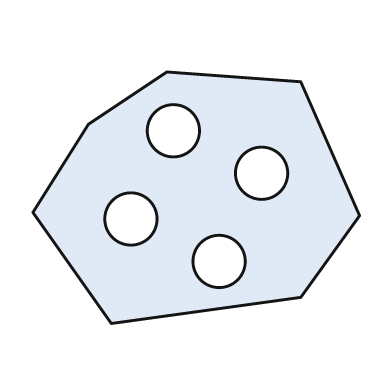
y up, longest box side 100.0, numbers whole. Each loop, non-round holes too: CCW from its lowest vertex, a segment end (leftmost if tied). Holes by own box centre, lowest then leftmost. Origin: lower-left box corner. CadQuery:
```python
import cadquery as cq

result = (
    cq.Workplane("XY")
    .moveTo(24.0, 0.0)
    .lineTo(82.0, 8.0)
    .lineTo(100.0, 33.0)
    .lineTo(82.0, 74.0)
    .lineTo(41.0, 77.0)
    .lineTo(17.0, 61.0)
    .lineTo(0.0, 34.0)
    .close()
    .moveTo(57.0, 19.0)
    .circle(8.0)
    .moveTo(30.0, 32.0)
    .circle(8.0)
    .moveTo(70.0, 46.0)
    .circle(8.0)
    .moveTo(43.0, 59.0)
    .circle(8.0)
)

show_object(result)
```